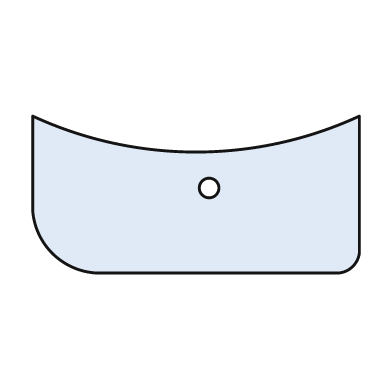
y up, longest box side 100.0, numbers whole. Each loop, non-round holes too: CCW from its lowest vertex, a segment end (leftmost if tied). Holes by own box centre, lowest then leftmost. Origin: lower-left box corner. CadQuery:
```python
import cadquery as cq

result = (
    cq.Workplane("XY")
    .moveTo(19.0, 0.0)
    .lineTo(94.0, 0.0)
    .threePointArc((98.0, 2.0), (100.0, 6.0))
    .lineTo(100.0, 48.0)
    .threePointArc((50.0, 37.0), (0.0, 48.0))
    .lineTo(0.0, 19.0)
    .threePointArc((6.0, 6.0), (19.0, 0.0))
    .close()
    .moveTo(54.0, 26.0)
    .circle(3.0)
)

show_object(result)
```